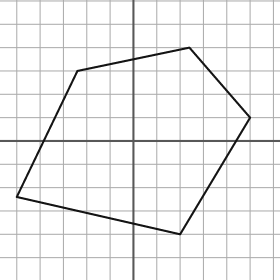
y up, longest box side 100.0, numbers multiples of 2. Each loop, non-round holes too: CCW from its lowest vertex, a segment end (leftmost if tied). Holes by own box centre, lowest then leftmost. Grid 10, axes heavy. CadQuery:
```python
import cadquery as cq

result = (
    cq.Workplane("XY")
    .moveTo(20.0, -40.0)
    .lineTo(50.0, 10.0)
    .lineTo(24.0, 40.0)
    .lineTo(-24.0, 30.0)
    .lineTo(-50.0, -24.0)
    .close()
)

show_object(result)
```